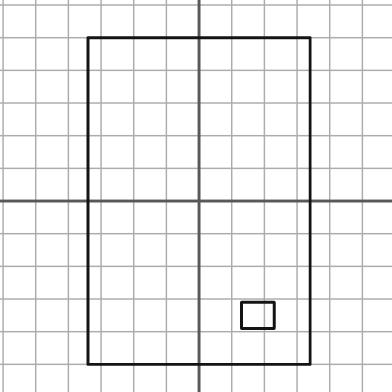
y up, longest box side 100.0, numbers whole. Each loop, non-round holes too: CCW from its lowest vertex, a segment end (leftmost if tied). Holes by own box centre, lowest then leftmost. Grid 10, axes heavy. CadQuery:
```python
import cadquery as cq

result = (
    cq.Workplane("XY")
    .moveTo(-34.0, -50.0)
    .lineTo(34.0, -50.0)
    .lineTo(34.0, 50.0)
    .lineTo(-34.0, 50.0)
    .close()
    .moveTo(13.0, -39.0)
    .lineTo(23.0, -39.0)
    .lineTo(23.0, -31.0)
    .lineTo(13.0, -31.0)
    .close()
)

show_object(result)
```